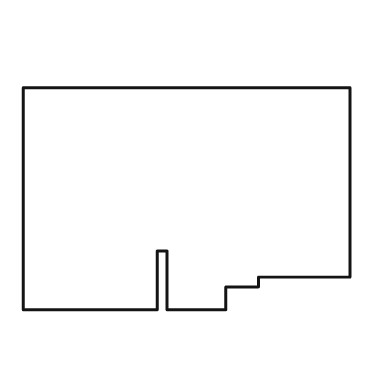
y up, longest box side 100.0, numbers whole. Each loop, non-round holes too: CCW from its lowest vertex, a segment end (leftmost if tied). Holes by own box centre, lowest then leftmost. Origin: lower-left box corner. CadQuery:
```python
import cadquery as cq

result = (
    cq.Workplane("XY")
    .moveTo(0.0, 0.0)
    .lineTo(41.0, 0.0)
    .lineTo(41.0, 18.0)
    .lineTo(44.0, 18.0)
    .lineTo(44.0, 0.0)
    .lineTo(62.0, 0.0)
    .lineTo(62.0, 7.0)
    .lineTo(72.0, 7.0)
    .lineTo(72.0, 10.0)
    .lineTo(100.0, 10.0)
    .lineTo(100.0, 68.0)
    .lineTo(0.0, 68.0)
    .close()
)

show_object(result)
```